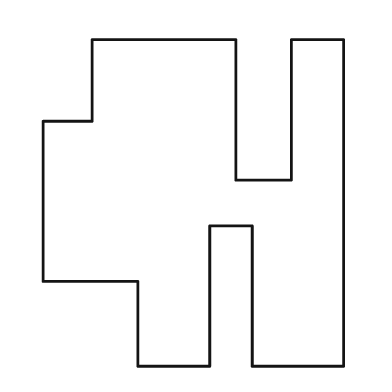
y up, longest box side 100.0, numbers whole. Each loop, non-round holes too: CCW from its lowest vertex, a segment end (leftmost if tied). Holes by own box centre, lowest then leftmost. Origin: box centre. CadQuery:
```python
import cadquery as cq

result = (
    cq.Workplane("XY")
    .moveTo(-17.0, -50.0)
    .lineTo(5.0, -50.0)
    .lineTo(5.0, -7.0)
    .lineTo(18.0, -7.0)
    .lineTo(18.0, -50.0)
    .lineTo(46.0, -50.0)
    .lineTo(46.0, 50.0)
    .lineTo(30.0, 50.0)
    .lineTo(30.0, 7.0)
    .lineTo(13.0, 7.0)
    .lineTo(13.0, 50.0)
    .lineTo(-31.0, 50.0)
    .lineTo(-31.0, 25.0)
    .lineTo(-46.0, 25.0)
    .lineTo(-46.0, -24.0)
    .lineTo(-17.0, -24.0)
    .close()
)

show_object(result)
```